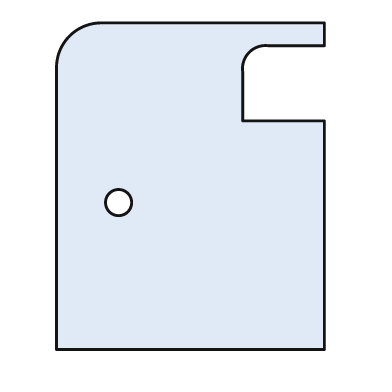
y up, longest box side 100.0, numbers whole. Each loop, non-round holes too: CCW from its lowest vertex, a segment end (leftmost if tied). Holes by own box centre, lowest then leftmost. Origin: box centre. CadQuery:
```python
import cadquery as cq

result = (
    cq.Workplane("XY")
    .moveTo(-41.0, -50.0)
    .lineTo(41.0, -50.0)
    .lineTo(41.0, 20.0)
    .lineTo(16.0, 20.0)
    .lineTo(16.0, 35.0)
    .threePointArc((18.0, 41.0), (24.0, 43.0))
    .lineTo(41.0, 43.0)
    .lineTo(41.0, 50.0)
    .lineTo(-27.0, 50.0)
    .threePointArc((-37.0, 46.0), (-41.0, 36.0))
    .close()
    .moveTo(-22.0, -5.0)
    .circle(4.0)
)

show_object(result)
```